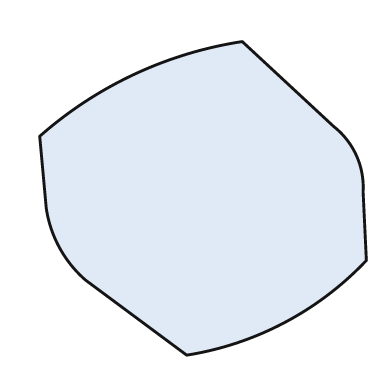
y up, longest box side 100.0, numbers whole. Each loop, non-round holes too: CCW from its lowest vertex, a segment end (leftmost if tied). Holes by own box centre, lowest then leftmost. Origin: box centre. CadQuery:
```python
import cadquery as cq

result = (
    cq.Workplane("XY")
    .moveTo(-5.0, -48.0)
    .threePointArc((25.0, -38.0), (50.0, -19.0))
    .lineTo(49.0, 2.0)
    .threePointArc((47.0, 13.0), (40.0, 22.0))
    .lineTo(12.0, 48.0)
    .threePointArc((-21.0, 38.0), (-50.0, 19.0))
    .lineTo(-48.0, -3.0)
    .threePointArc((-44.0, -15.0), (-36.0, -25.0))
    .close()
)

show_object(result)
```